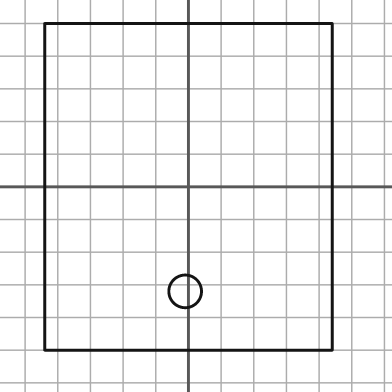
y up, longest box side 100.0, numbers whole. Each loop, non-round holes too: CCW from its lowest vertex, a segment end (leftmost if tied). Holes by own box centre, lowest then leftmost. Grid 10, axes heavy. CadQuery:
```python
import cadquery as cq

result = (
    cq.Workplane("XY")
    .moveTo(-44.0, -50.0)
    .lineTo(44.0, -50.0)
    .lineTo(44.0, 50.0)
    .lineTo(-44.0, 50.0)
    .close()
    .moveTo(-1.0, -32.0)
    .circle(5.0)
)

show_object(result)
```